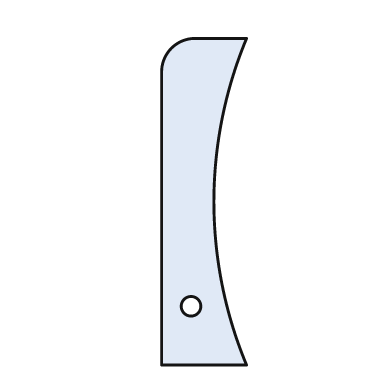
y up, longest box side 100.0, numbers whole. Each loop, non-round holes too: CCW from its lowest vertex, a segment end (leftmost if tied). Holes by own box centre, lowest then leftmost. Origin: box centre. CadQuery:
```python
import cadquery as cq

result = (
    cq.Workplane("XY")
    .moveTo(-13.0, -50.0)
    .lineTo(13.0, -50.0)
    .threePointArc((3.0, 0.0), (13.0, 50.0))
    .lineTo(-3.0, 50.0)
    .threePointArc((-10.0, 47.0), (-13.0, 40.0))
    .close()
    .moveTo(-4.0, -32.0)
    .circle(3.0)
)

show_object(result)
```